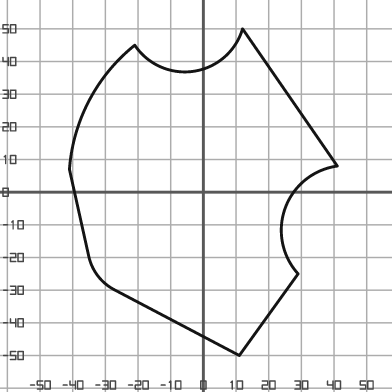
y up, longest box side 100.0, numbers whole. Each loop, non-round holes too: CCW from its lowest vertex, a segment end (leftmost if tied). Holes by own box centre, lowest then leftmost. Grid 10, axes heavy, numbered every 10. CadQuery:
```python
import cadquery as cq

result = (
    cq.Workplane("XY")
    .moveTo(11.0, -50.0)
    .lineTo(29.0, -25.0)
    .threePointArc((25.0, -5.0), (41.0, 8.0))
    .lineTo(12.0, 50.0)
    .threePointArc((-3.0, 37.0), (-21.0, 45.0))
    .threePointArc((-35.0, 28.0), (-41.0, 7.0))
    .lineTo(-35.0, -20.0)
    .threePointArc((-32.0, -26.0), (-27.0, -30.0))
    .close()
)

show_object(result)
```